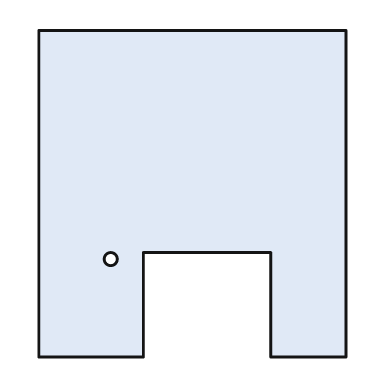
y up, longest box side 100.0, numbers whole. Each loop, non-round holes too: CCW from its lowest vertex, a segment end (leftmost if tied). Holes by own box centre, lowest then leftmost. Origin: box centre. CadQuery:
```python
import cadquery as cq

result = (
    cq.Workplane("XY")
    .moveTo(-47.0, -50.0)
    .lineTo(-15.0, -50.0)
    .lineTo(-15.0, -18.0)
    .lineTo(24.0, -18.0)
    .lineTo(24.0, -50.0)
    .lineTo(47.0, -50.0)
    .lineTo(47.0, 50.0)
    .lineTo(-47.0, 50.0)
    .close()
    .moveTo(-25.0, -20.0)
    .circle(2.0)
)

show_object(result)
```